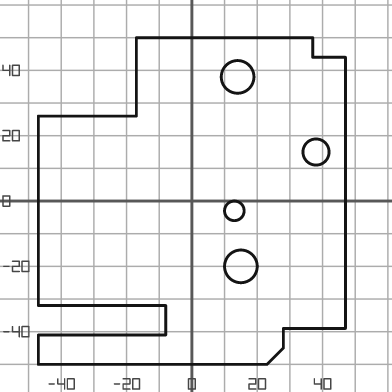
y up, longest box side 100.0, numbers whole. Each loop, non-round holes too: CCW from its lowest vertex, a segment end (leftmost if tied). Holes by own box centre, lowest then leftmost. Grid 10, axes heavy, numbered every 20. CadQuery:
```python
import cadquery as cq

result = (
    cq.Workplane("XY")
    .moveTo(-47.0, -50.0)
    .lineTo(23.0, -50.0)
    .lineTo(28.0, -45.0)
    .lineTo(28.0, -39.0)
    .lineTo(47.0, -39.0)
    .lineTo(47.0, 44.0)
    .lineTo(37.0, 44.0)
    .lineTo(37.0, 50.0)
    .lineTo(-17.0, 50.0)
    .lineTo(-17.0, 26.0)
    .lineTo(-47.0, 26.0)
    .lineTo(-47.0, -32.0)
    .lineTo(-8.0, -32.0)
    .lineTo(-8.0, -41.0)
    .lineTo(-47.0, -41.0)
    .close()
    .moveTo(15.0, -20.0)
    .circle(5.0)
    .moveTo(13.0, -3.0)
    .circle(3.0)
    .moveTo(38.0, 15.0)
    .circle(4.0)
    .moveTo(14.0, 38.0)
    .circle(5.0)
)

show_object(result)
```